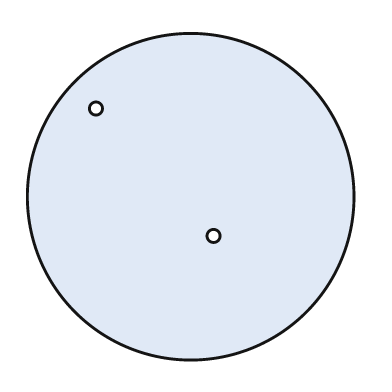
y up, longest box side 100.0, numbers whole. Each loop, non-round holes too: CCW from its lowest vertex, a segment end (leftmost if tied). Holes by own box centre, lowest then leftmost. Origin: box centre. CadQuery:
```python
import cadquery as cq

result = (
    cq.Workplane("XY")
    .moveTo(0.0, 0.0)
    .circle(50.0)
    .moveTo(7.0, -12.0)
    .circle(2.0)
    .moveTo(-29.0, 27.0)
    .circle(2.0)
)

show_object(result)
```